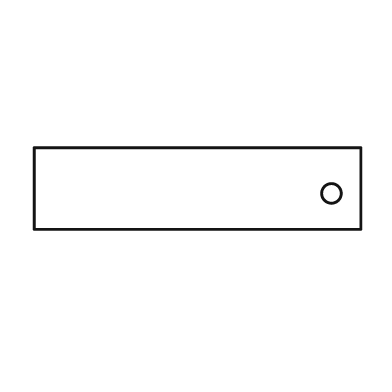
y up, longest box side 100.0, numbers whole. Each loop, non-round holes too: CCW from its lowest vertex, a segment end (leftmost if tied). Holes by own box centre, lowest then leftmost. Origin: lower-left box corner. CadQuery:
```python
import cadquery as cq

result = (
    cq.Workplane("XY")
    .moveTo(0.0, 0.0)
    .lineTo(100.0, 0.0)
    .lineTo(100.0, 25.0)
    .lineTo(0.0, 25.0)
    .close()
    .moveTo(91.0, 11.0)
    .circle(3.0)
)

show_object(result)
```